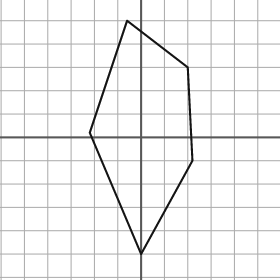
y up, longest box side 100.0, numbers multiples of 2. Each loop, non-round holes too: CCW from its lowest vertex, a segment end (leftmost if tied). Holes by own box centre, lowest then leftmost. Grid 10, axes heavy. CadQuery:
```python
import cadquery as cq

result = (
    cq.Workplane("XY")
    .moveTo(0.0, -50.0)
    .lineTo(22.0, -10.0)
    .lineTo(20.0, 30.0)
    .lineTo(-6.0, 50.0)
    .lineTo(-22.0, 2.0)
    .close()
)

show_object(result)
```